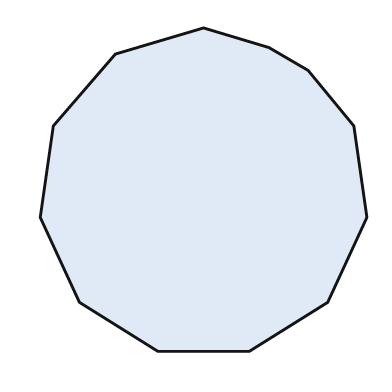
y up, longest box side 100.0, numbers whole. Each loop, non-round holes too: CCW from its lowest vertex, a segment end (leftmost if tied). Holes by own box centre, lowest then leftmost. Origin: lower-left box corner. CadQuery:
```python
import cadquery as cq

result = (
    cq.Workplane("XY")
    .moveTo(36.0, 0.0)
    .lineTo(64.0, 0.0)
    .lineTo(88.0, 15.0)
    .lineTo(100.0, 41.0)
    .lineTo(96.0, 69.0)
    .lineTo(82.0, 86.0)
    .lineTo(70.0, 93.0)
    .lineTo(50.0, 99.0)
    .lineTo(23.0, 91.0)
    .lineTo(4.0, 69.0)
    .lineTo(0.0, 41.0)
    .lineTo(12.0, 15.0)
    .close()
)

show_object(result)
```